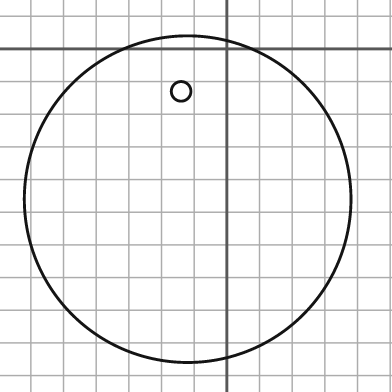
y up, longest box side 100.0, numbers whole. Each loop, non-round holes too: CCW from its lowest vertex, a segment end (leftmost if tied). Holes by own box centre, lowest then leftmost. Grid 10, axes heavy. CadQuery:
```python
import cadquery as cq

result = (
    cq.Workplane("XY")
    .moveTo(-12.0, -46.0)
    .circle(50.0)
    .moveTo(-14.0, -13.0)
    .circle(3.0)
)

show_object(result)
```